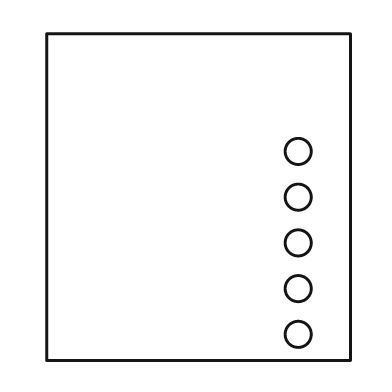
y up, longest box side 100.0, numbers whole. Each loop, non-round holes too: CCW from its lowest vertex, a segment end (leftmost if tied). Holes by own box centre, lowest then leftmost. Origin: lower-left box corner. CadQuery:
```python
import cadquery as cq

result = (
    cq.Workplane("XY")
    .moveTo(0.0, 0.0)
    .lineTo(93.0, 0.0)
    .lineTo(93.0, 100.0)
    .lineTo(0.0, 100.0)
    .close()
    .moveTo(77.0, 8.0)
    .circle(4.0)
    .moveTo(77.0, 22.0)
    .circle(4.0)
    .moveTo(77.0, 36.0)
    .circle(4.0)
    .moveTo(77.0, 50.0)
    .circle(4.0)
    .moveTo(77.0, 64.0)
    .circle(4.0)
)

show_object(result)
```